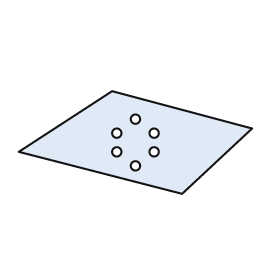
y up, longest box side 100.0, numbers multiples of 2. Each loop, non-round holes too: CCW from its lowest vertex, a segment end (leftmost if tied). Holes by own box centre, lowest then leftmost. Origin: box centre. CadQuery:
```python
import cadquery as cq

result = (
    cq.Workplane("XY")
    .moveTo(20.0, -22.0)
    .lineTo(50.0, 6.0)
    .lineTo(-10.0, 22.0)
    .lineTo(-50.0, -4.0)
    .close()
    .moveTo(0.0, -10.0)
    .circle(2.0)
    .moveTo(-8.0, -4.0)
    .circle(2.0)
    .moveTo(8.0, -4.0)
    .circle(2.0)
    .moveTo(-8.0, 4.0)
    .circle(2.0)
    .moveTo(8.0, 4.0)
    .circle(2.0)
    .moveTo(0.0, 10.0)
    .circle(2.0)
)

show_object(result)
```